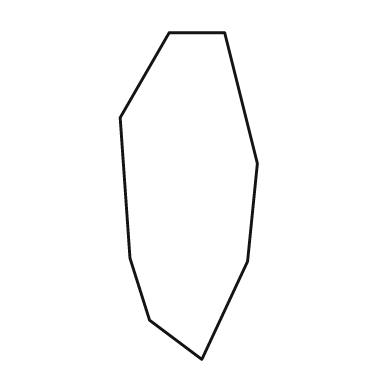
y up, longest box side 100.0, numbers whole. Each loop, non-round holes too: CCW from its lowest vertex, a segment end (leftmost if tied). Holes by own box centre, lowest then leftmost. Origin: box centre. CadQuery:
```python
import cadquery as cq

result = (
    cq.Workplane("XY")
    .moveTo(4.0, -50.0)
    .lineTo(18.0, -20.0)
    .lineTo(21.0, 10.0)
    .lineTo(11.0, 50.0)
    .lineTo(-6.0, 50.0)
    .lineTo(-21.0, 24.0)
    .lineTo(-18.0, -19.0)
    .lineTo(-12.0, -38.0)
    .close()
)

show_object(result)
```